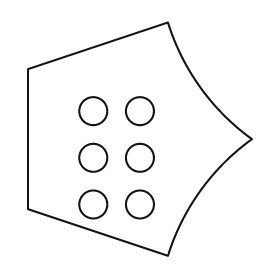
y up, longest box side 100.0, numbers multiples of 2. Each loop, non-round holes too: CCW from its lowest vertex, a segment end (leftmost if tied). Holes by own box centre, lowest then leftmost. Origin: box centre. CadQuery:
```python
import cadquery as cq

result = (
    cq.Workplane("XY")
    .moveTo(12.0, -50.0)
    .threePointArc((26.0, -22.0), (48.0, 0.0))
    .threePointArc((26.0, 22.0), (12.0, 50.0))
    .lineTo(-48.0, 30.0)
    .lineTo(-48.0, -30.0)
    .close()
    .moveTo(-20.0, -28.0)
    .circle(6.0)
    .moveTo(0.0, -28.0)
    .circle(6.0)
    .moveTo(-20.0, -8.0)
    .circle(6.0)
    .moveTo(0.0, -8.0)
    .circle(6.0)
    .moveTo(-20.0, 12.0)
    .circle(6.0)
    .moveTo(0.0, 12.0)
    .circle(6.0)
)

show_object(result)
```